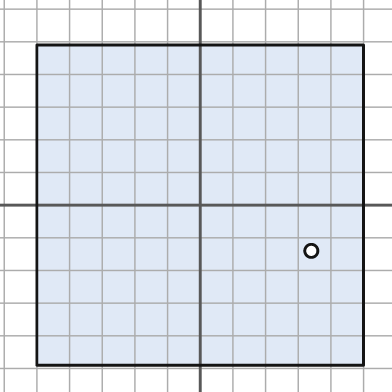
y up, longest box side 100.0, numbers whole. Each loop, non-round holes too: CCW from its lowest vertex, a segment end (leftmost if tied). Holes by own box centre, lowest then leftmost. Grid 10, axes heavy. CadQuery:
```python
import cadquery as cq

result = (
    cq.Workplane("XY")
    .moveTo(-50.0, -49.0)
    .lineTo(50.0, -49.0)
    .lineTo(50.0, 49.0)
    .lineTo(-50.0, 49.0)
    .close()
    .moveTo(34.0, -14.0)
    .circle(2.0)
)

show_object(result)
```